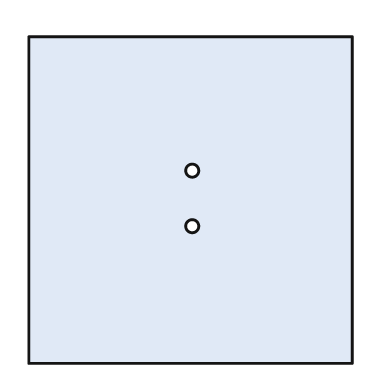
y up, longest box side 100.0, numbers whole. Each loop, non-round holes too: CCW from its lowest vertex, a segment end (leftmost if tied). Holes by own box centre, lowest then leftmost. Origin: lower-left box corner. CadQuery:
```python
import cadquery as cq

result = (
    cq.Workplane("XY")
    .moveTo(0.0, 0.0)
    .lineTo(99.0, 0.0)
    .lineTo(99.0, 100.0)
    .lineTo(0.0, 100.0)
    .close()
    .moveTo(50.0, 42.0)
    .circle(2.0)
    .moveTo(50.0, 59.0)
    .circle(2.0)
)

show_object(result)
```